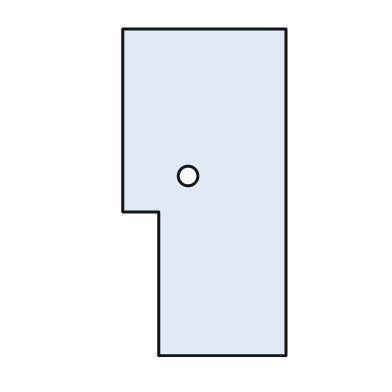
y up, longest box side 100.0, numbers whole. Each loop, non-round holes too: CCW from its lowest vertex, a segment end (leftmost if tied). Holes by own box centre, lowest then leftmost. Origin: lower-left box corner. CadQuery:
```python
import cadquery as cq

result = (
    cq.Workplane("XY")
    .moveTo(11.0, 0.0)
    .lineTo(50.0, 0.0)
    .lineTo(50.0, 100.0)
    .lineTo(0.0, 100.0)
    .lineTo(0.0, 44.0)
    .lineTo(11.0, 44.0)
    .close()
    .moveTo(20.0, 55.0)
    .circle(3.0)
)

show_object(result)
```